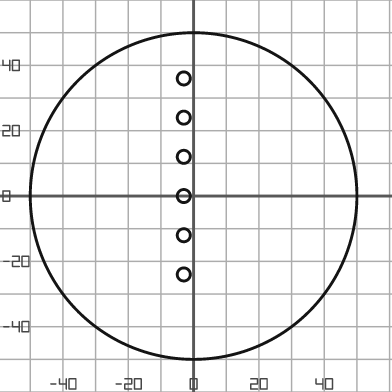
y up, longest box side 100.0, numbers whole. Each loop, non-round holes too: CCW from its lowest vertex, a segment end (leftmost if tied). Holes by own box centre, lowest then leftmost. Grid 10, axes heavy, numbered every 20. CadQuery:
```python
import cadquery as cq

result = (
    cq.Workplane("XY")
    .moveTo(0.0, 0.0)
    .circle(50.0)
    .moveTo(-3.0, -24.0)
    .circle(2.0)
    .moveTo(-3.0, -12.0)
    .circle(2.0)
    .moveTo(-3.0, 0.0)
    .circle(2.0)
    .moveTo(-3.0, 12.0)
    .circle(2.0)
    .moveTo(-3.0, 24.0)
    .circle(2.0)
    .moveTo(-3.0, 36.0)
    .circle(2.0)
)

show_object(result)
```